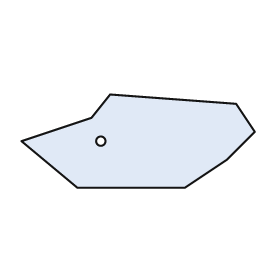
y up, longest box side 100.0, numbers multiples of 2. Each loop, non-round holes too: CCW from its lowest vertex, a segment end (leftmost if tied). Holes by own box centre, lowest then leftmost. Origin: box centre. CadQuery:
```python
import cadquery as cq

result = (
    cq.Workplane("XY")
    .moveTo(-26.0, -20.0)
    .lineTo(20.0, -20.0)
    .lineTo(38.0, -8.0)
    .lineTo(50.0, 4.0)
    .lineTo(42.0, 16.0)
    .lineTo(-12.0, 20.0)
    .lineTo(-20.0, 10.0)
    .lineTo(-50.0, 0.0)
    .close()
    .moveTo(-16.0, 0.0)
    .circle(2.0)
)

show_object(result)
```